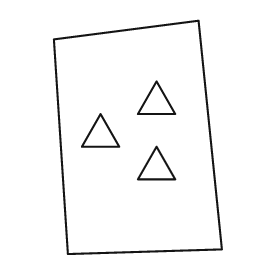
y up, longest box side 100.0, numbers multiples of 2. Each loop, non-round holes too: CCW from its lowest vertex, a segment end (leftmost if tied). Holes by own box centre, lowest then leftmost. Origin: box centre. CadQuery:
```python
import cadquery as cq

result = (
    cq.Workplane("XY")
    .moveTo(-30.0, -50.0)
    .lineTo(36.0, -48.0)
    .lineTo(26.0, 50.0)
    .lineTo(-36.0, 42.0)
    .close()
    .moveTo(0.0, -18.0)
    .lineTo(16.0, -18.0)
    .lineTo(8.0, -4.0)
    .close()
    .moveTo(-24.0, -4.0)
    .lineTo(-8.0, -4.0)
    .lineTo(-16.0, 10.0)
    .close()
    .moveTo(0.0, 10.0)
    .lineTo(16.0, 10.0)
    .lineTo(8.0, 24.0)
    .close()
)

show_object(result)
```